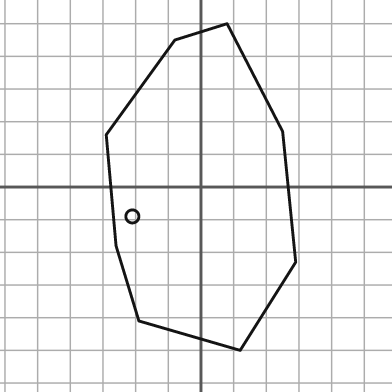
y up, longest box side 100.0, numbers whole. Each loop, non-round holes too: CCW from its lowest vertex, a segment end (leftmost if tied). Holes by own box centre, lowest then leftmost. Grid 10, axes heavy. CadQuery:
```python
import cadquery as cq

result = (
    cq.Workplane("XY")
    .moveTo(12.0, -50.0)
    .lineTo(29.0, -23.0)
    .lineTo(25.0, 17.0)
    .lineTo(8.0, 50.0)
    .lineTo(-8.0, 45.0)
    .lineTo(-29.0, 16.0)
    .lineTo(-26.0, -18.0)
    .lineTo(-19.0, -41.0)
    .close()
    .moveTo(-21.0, -9.0)
    .circle(2.0)
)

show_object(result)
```